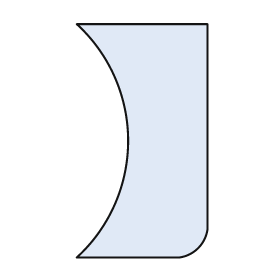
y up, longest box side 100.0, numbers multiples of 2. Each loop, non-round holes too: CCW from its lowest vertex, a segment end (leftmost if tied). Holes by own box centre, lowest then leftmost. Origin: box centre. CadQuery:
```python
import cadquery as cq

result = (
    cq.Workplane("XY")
    .moveTo(-28.0, -50.0)
    .lineTo(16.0, -50.0)
    .threePointArc((24.0, -46.0), (28.0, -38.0))
    .lineTo(28.0, 50.0)
    .lineTo(-28.0, 50.0)
    .threePointArc((-6.0, 0.0), (-28.0, -50.0))
    .close()
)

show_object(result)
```